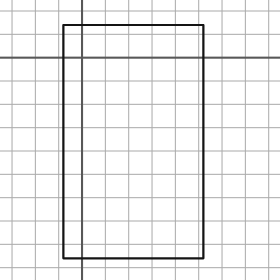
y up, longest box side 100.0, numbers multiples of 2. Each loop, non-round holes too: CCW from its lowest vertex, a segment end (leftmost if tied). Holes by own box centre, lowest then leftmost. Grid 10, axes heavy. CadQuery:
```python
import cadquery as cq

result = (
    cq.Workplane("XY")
    .moveTo(-8.0, -86.0)
    .lineTo(52.0, -86.0)
    .lineTo(52.0, 14.0)
    .lineTo(-8.0, 14.0)
    .close()
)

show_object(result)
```